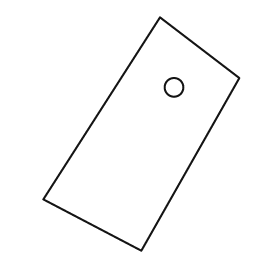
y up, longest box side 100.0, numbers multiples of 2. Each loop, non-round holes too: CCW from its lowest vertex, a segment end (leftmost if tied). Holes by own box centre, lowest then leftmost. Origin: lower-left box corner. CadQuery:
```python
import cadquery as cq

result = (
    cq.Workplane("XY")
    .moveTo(42.0, 0.0)
    .lineTo(84.0, 74.0)
    .lineTo(50.0, 100.0)
    .lineTo(0.0, 22.0)
    .close()
    .moveTo(56.0, 70.0)
    .circle(4.0)
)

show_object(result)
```